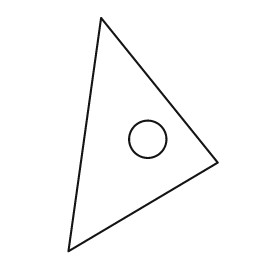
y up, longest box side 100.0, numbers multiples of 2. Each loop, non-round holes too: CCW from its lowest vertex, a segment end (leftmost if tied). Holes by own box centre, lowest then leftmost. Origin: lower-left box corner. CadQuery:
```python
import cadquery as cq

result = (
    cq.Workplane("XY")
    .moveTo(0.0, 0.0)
    .lineTo(64.0, 38.0)
    .lineTo(14.0, 100.0)
    .close()
    .moveTo(34.0, 48.0)
    .circle(8.0)
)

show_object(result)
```